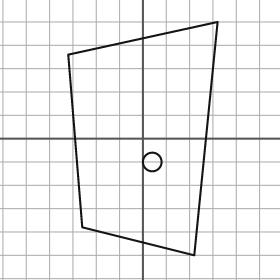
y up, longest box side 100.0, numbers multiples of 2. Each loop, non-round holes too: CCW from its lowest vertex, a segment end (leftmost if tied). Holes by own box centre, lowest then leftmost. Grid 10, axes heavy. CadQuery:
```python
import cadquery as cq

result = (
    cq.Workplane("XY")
    .moveTo(22.0, -50.0)
    .lineTo(32.0, 50.0)
    .lineTo(-32.0, 36.0)
    .lineTo(-26.0, -38.0)
    .close()
    .moveTo(4.0, -10.0)
    .circle(4.0)
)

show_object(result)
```